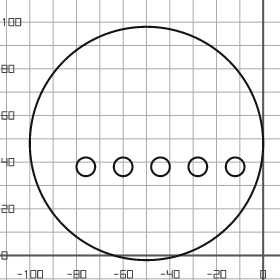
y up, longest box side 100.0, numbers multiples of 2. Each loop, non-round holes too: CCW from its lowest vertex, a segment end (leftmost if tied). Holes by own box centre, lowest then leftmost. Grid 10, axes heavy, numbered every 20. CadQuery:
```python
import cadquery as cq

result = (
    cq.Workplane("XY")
    .moveTo(-50.0, 48.0)
    .circle(50.0)
    .moveTo(-76.0, 38.0)
    .circle(4.0)
    .moveTo(-60.0, 38.0)
    .circle(4.0)
    .moveTo(-44.0, 38.0)
    .circle(4.0)
    .moveTo(-28.0, 38.0)
    .circle(4.0)
    .moveTo(-12.0, 38.0)
    .circle(4.0)
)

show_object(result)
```